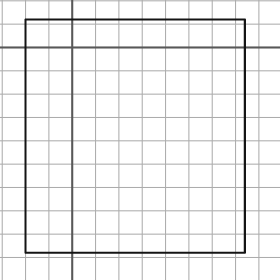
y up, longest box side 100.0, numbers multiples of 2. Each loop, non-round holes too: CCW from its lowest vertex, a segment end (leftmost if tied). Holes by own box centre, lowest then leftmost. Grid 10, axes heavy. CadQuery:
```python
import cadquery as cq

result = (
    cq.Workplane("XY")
    .moveTo(-20.0, -88.0)
    .lineTo(74.0, -88.0)
    .lineTo(74.0, 12.0)
    .lineTo(-20.0, 12.0)
    .close()
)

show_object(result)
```